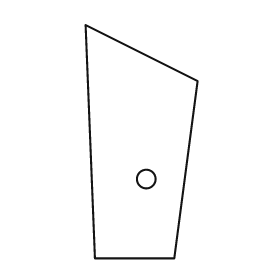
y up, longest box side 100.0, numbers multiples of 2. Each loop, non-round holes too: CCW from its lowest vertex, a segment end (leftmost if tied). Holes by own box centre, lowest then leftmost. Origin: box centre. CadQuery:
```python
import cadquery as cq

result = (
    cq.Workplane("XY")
    .moveTo(-20.0, -50.0)
    .lineTo(14.0, -50.0)
    .lineTo(24.0, 26.0)
    .lineTo(-24.0, 50.0)
    .close()
    .moveTo(2.0, -16.0)
    .circle(4.0)
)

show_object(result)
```